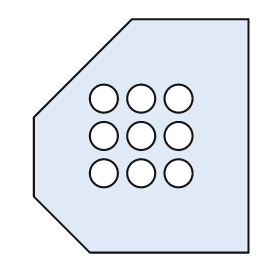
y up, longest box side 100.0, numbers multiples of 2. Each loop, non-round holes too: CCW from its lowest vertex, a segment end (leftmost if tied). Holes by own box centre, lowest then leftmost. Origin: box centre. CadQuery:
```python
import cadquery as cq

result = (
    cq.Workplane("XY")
    .moveTo(-22.0, -50.0)
    .lineTo(46.0, -50.0)
    .lineTo(46.0, 50.0)
    .lineTo(-4.0, 50.0)
    .lineTo(-46.0, 8.0)
    .lineTo(-46.0, -26.0)
    .close()
    .moveTo(-16.0, -16.0)
    .circle(6.0)
    .moveTo(0.0, -16.0)
    .circle(6.0)
    .moveTo(16.0, -16.0)
    .circle(6.0)
    .moveTo(-16.0, 0.0)
    .circle(6.0)
    .moveTo(0.0, 0.0)
    .circle(6.0)
    .moveTo(16.0, 0.0)
    .circle(6.0)
    .moveTo(-16.0, 16.0)
    .circle(6.0)
    .moveTo(0.0, 16.0)
    .circle(6.0)
    .moveTo(16.0, 16.0)
    .circle(6.0)
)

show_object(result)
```